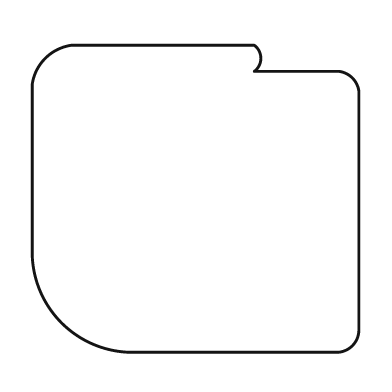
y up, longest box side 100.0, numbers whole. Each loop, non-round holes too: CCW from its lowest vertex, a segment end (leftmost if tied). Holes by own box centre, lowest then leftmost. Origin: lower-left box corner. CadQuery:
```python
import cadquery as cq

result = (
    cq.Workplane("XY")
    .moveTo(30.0, 0.0)
    .lineTo(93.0, 0.0)
    .threePointArc((98.0, 2.0), (100.0, 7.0))
    .lineTo(100.0, 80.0)
    .threePointArc((98.0, 84.0), (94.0, 86.0))
    .lineTo(68.0, 86.0)
    .threePointArc((70.0, 90.0), (68.0, 94.0))
    .lineTo(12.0, 94.0)
    .threePointArc((4.0, 90.0), (0.0, 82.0))
    .lineTo(0.0, 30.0)
    .threePointArc((9.0, 9.0), (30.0, 0.0))
    .close()
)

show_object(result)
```